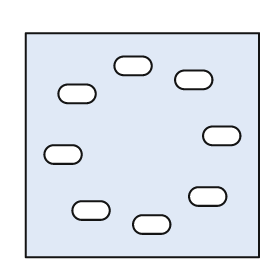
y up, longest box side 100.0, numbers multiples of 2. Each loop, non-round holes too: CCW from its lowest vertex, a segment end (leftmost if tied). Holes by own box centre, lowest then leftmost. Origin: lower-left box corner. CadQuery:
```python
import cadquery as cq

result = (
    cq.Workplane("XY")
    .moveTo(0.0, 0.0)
    .lineTo(100.0, 0.0)
    .lineTo(100.0, 96.0)
    .lineTo(0.0, 96.0)
    .close()
    .moveTo(50.0, 10.0)
    .lineTo(58.0, 10.0)
    .threePointArc((62.0, 14.0), (58.0, 18.0))
    .lineTo(50.0, 18.0)
    .threePointArc((46.0, 14.0), (50.0, 10.0))
    .close()
    .moveTo(24.0, 16.0)
    .lineTo(32.0, 16.0)
    .threePointArc((36.0, 20.0), (32.0, 24.0))
    .lineTo(24.0, 24.0)
    .threePointArc((20.0, 20.0), (24.0, 16.0))
    .close()
    .moveTo(74.0, 22.0)
    .lineTo(82.0, 22.0)
    .threePointArc((86.0, 26.0), (82.0, 30.0))
    .lineTo(74.0, 30.0)
    .threePointArc((70.0, 26.0), (74.0, 22.0))
    .close()
    .moveTo(12.0, 40.0)
    .lineTo(20.0, 40.0)
    .threePointArc((24.0, 44.0), (20.0, 48.0))
    .lineTo(12.0, 48.0)
    .threePointArc((8.0, 44.0), (12.0, 40.0))
    .close()
    .moveTo(80.0, 48.0)
    .lineTo(88.0, 48.0)
    .threePointArc((92.0, 52.0), (88.0, 56.0))
    .lineTo(80.0, 56.0)
    .threePointArc((76.0, 52.0), (80.0, 48.0))
    .close()
    .moveTo(18.0, 66.0)
    .lineTo(26.0, 66.0)
    .threePointArc((30.0, 70.0), (26.0, 74.0))
    .lineTo(18.0, 74.0)
    .threePointArc((14.0, 70.0), (18.0, 66.0))
    .close()
    .moveTo(68.0, 72.0)
    .lineTo(76.0, 72.0)
    .threePointArc((80.0, 76.0), (76.0, 80.0))
    .lineTo(68.0, 80.0)
    .threePointArc((64.0, 76.0), (68.0, 72.0))
    .close()
    .moveTo(42.0, 78.0)
    .lineTo(50.0, 78.0)
    .threePointArc((54.0, 82.0), (50.0, 86.0))
    .lineTo(42.0, 86.0)
    .threePointArc((38.0, 82.0), (42.0, 78.0))
    .close()
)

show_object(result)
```